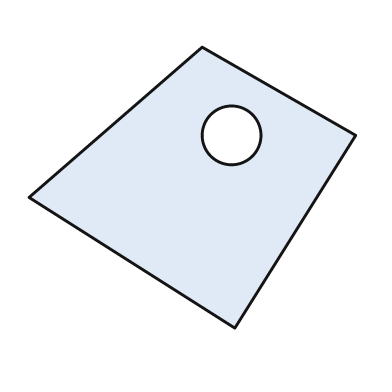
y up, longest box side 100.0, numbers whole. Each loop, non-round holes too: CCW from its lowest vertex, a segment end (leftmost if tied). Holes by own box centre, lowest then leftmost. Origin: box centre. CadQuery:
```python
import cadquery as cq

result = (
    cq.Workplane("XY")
    .moveTo(13.0, -43.0)
    .lineTo(50.0, 16.0)
    .lineTo(3.0, 43.0)
    .lineTo(-50.0, -3.0)
    .close()
    .moveTo(12.0, 16.0)
    .circle(9.0)
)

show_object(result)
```